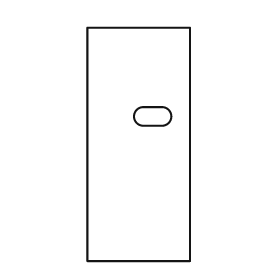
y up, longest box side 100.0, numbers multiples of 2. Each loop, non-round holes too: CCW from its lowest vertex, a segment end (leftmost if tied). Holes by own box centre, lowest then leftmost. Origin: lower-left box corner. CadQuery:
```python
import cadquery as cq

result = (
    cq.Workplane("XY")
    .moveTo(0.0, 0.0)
    .lineTo(44.0, 0.0)
    .lineTo(44.0, 100.0)
    .lineTo(0.0, 100.0)
    .close()
    .moveTo(24.0, 58.0)
    .lineTo(32.0, 58.0)
    .threePointArc((36.0, 62.0), (32.0, 66.0))
    .lineTo(24.0, 66.0)
    .threePointArc((20.0, 62.0), (24.0, 58.0))
    .close()
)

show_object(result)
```